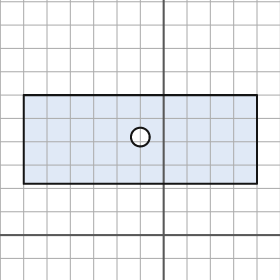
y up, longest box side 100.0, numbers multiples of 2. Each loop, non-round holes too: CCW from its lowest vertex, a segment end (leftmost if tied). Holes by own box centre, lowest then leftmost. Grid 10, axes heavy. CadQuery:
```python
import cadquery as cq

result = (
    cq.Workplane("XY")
    .moveTo(-60.0, 22.0)
    .lineTo(40.0, 22.0)
    .lineTo(40.0, 60.0)
    .lineTo(-60.0, 60.0)
    .close()
    .moveTo(-10.0, 42.0)
    .circle(4.0)
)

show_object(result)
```